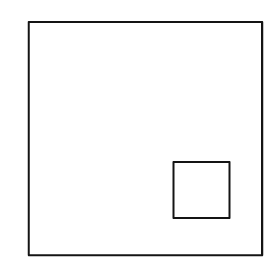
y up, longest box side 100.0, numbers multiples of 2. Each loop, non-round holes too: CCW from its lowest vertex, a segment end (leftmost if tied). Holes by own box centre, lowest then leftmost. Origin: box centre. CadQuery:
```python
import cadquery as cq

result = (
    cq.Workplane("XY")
    .moveTo(-50.0, -50.0)
    .lineTo(50.0, -50.0)
    .lineTo(50.0, 50.0)
    .lineTo(-50.0, 50.0)
    .close()
    .moveTo(12.0, -34.0)
    .lineTo(36.0, -34.0)
    .lineTo(36.0, -10.0)
    .lineTo(12.0, -10.0)
    .close()
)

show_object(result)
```